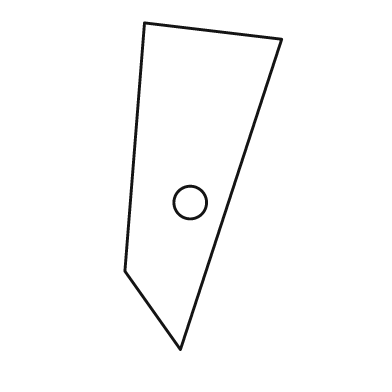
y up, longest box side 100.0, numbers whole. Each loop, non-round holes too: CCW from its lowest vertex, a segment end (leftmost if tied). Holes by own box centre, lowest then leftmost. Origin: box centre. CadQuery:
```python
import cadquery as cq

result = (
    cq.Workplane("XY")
    .moveTo(-7.0, -50.0)
    .lineTo(24.0, 45.0)
    .lineTo(-18.0, 50.0)
    .lineTo(-24.0, -26.0)
    .close()
    .moveTo(-4.0, -5.0)
    .circle(5.0)
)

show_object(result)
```